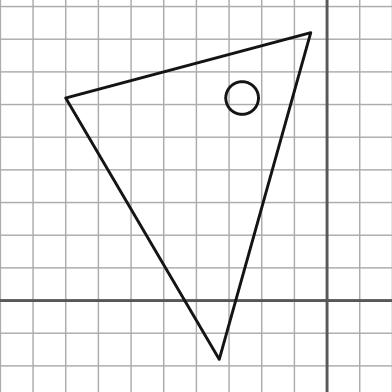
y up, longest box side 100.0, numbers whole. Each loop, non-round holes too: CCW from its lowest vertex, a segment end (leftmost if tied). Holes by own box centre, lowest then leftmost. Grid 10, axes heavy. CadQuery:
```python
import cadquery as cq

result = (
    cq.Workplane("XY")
    .moveTo(-33.0, -18.0)
    .lineTo(-5.0, 82.0)
    .lineTo(-80.0, 62.0)
    .close()
    .moveTo(-26.0, 62.0)
    .circle(5.0)
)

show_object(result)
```